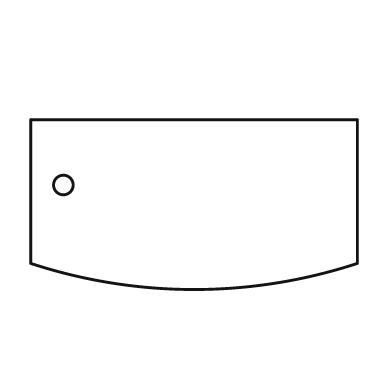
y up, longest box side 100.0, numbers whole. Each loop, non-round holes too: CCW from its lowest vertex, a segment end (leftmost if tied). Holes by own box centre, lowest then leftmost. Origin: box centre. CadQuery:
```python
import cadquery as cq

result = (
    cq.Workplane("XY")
    .moveTo(-50.0, -18.0)
    .threePointArc((0.0, -26.0), (50.0, -18.0))
    .lineTo(50.0, 26.0)
    .lineTo(-50.0, 26.0)
    .close()
    .moveTo(-40.0, 6.0)
    .circle(3.0)
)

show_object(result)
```